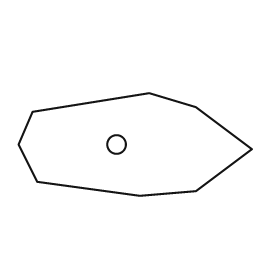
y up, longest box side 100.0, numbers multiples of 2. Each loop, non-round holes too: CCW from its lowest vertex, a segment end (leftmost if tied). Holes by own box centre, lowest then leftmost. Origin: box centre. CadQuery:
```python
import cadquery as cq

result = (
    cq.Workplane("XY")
    .moveTo(2.0, -22.0)
    .lineTo(26.0, -20.0)
    .lineTo(50.0, -2.0)
    .lineTo(26.0, 16.0)
    .lineTo(6.0, 22.0)
    .lineTo(-44.0, 14.0)
    .lineTo(-50.0, 0.0)
    .lineTo(-42.0, -16.0)
    .close()
    .moveTo(-8.0, 0.0)
    .circle(4.0)
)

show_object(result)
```